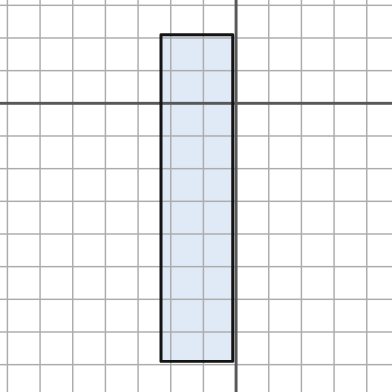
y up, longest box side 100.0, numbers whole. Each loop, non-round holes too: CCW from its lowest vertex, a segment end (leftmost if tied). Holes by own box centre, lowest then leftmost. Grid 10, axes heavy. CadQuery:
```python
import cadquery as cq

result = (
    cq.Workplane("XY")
    .moveTo(-23.0, -79.0)
    .lineTo(-1.0, -79.0)
    .lineTo(-1.0, 21.0)
    .lineTo(-23.0, 21.0)
    .close()
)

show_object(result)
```